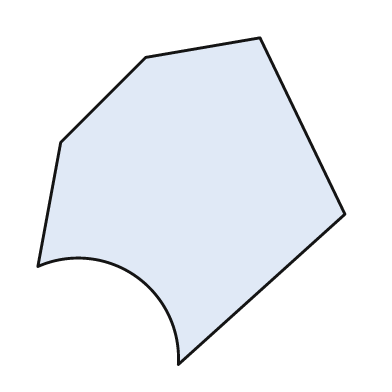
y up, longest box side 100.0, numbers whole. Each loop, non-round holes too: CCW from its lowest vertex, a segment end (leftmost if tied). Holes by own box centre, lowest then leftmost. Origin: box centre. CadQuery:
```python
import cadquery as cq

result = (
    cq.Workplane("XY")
    .moveTo(-4.0, -50.0)
    .lineTo(47.0, -4.0)
    .lineTo(21.0, 50.0)
    .lineTo(-14.0, 44.0)
    .lineTo(-40.0, 18.0)
    .lineTo(-47.0, -20.0)
    .threePointArc((-17.0, -23.0), (-4.0, -50.0))
    .close()
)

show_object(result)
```